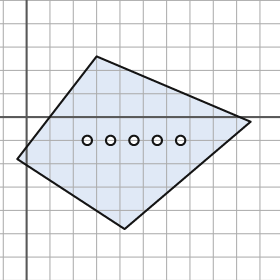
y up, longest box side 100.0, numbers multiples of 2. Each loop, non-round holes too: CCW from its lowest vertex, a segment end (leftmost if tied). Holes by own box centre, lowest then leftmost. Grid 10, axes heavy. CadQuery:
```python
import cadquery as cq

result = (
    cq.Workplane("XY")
    .moveTo(42.0, -48.0)
    .lineTo(96.0, -2.0)
    .lineTo(30.0, 26.0)
    .lineTo(-4.0, -18.0)
    .close()
    .moveTo(26.0, -10.0)
    .circle(2.0)
    .moveTo(36.0, -10.0)
    .circle(2.0)
    .moveTo(46.0, -10.0)
    .circle(2.0)
    .moveTo(56.0, -10.0)
    .circle(2.0)
    .moveTo(66.0, -10.0)
    .circle(2.0)
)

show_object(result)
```